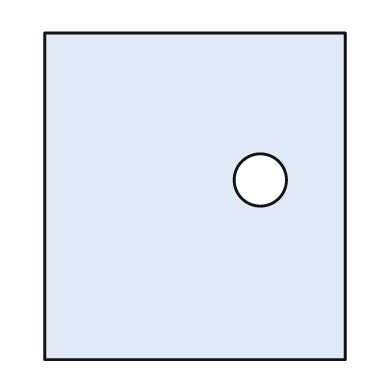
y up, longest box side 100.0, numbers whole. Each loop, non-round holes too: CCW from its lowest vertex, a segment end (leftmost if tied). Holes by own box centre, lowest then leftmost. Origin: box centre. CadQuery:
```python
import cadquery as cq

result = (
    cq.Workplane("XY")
    .moveTo(-46.0, -50.0)
    .lineTo(46.0, -50.0)
    .lineTo(46.0, 50.0)
    .lineTo(-46.0, 50.0)
    .close()
    .moveTo(20.0, 5.0)
    .circle(8.0)
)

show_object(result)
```